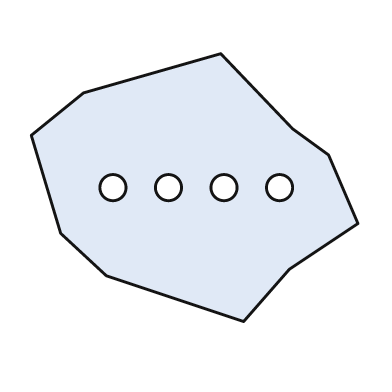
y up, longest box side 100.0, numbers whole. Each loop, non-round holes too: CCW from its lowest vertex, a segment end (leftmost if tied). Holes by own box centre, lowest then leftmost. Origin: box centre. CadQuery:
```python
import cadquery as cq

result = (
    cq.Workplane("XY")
    .moveTo(15.0, -41.0)
    .lineTo(29.0, -25.0)
    .lineTo(50.0, -11.0)
    .lineTo(41.0, 10.0)
    .lineTo(30.0, 18.0)
    .lineTo(8.0, 41.0)
    .lineTo(-34.0, 29.0)
    .lineTo(-50.0, 16.0)
    .lineTo(-41.0, -14.0)
    .lineTo(-27.0, -27.0)
    .close()
    .moveTo(-25.0, 0.0)
    .circle(4.0)
    .moveTo(-8.0, 0.0)
    .circle(4.0)
    .moveTo(9.0, 0.0)
    .circle(4.0)
    .moveTo(26.0, 0.0)
    .circle(4.0)
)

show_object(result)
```